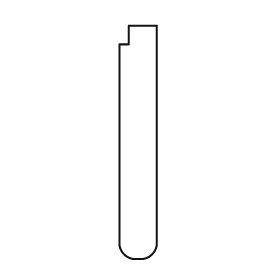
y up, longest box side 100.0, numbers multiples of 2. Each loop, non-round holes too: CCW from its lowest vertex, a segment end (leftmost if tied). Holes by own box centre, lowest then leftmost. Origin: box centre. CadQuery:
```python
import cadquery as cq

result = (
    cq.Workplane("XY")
    .moveTo(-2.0, -50.0)
    .lineTo(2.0, -50.0)
    .threePointArc((6.0, -48.0), (8.0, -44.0))
    .lineTo(8.0, 50.0)
    .lineTo(-4.0, 50.0)
    .lineTo(-4.0, 42.0)
    .lineTo(-8.0, 42.0)
    .lineTo(-8.0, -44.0)
    .threePointArc((-6.0, -48.0), (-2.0, -50.0))
    .close()
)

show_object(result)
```